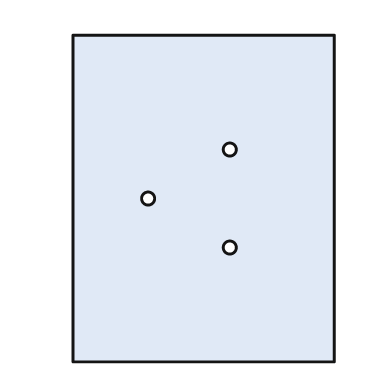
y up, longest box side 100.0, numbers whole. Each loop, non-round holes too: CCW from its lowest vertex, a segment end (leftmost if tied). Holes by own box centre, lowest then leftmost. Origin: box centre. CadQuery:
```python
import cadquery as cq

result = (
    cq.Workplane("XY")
    .moveTo(-40.0, -50.0)
    .lineTo(40.0, -50.0)
    .lineTo(40.0, 50.0)
    .lineTo(-40.0, 50.0)
    .close()
    .moveTo(8.0, -15.0)
    .circle(2.0)
    .moveTo(-17.0, 0.0)
    .circle(2.0)
    .moveTo(8.0, 15.0)
    .circle(2.0)
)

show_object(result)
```